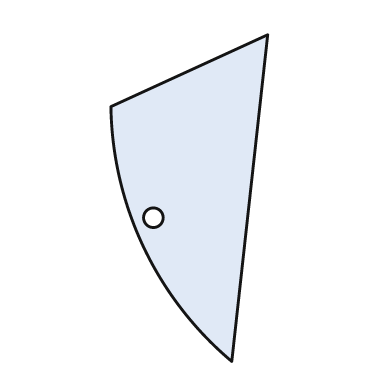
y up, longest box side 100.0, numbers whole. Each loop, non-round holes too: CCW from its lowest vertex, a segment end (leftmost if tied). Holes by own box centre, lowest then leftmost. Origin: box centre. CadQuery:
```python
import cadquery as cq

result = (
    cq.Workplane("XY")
    .moveTo(13.0, -50.0)
    .lineTo(24.0, 50.0)
    .lineTo(-24.0, 28.0)
    .threePointArc((-14.0, -15.0), (13.0, -50.0))
    .close()
    .moveTo(-11.0, -6.0)
    .circle(3.0)
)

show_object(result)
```